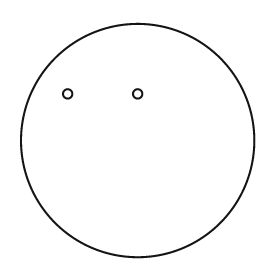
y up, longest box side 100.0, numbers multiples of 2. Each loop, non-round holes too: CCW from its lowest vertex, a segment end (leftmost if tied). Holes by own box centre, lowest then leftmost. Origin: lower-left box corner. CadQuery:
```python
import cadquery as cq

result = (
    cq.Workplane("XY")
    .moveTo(50.0, 50.0)
    .circle(50.0)
    .moveTo(20.0, 70.0)
    .circle(2.0)
    .moveTo(50.0, 70.0)
    .circle(2.0)
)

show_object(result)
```